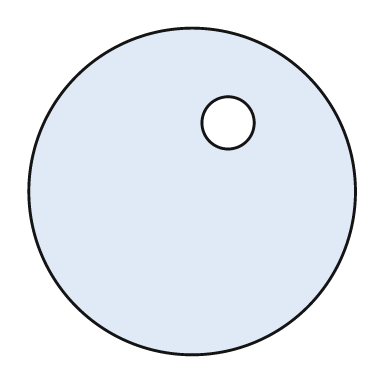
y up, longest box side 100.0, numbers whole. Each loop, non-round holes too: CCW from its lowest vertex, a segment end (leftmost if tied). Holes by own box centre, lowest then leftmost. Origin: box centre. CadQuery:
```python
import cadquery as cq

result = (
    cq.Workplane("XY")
    .moveTo(0.0, 0.0)
    .circle(50.0)
    .moveTo(11.0, 21.0)
    .circle(8.0)
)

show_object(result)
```